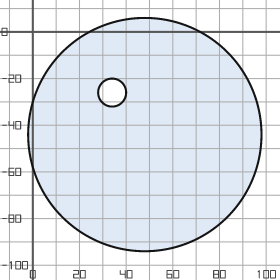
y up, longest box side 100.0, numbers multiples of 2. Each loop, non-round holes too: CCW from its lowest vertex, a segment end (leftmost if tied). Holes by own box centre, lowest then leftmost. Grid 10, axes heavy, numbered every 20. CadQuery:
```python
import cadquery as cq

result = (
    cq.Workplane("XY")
    .moveTo(48.0, -44.0)
    .circle(50.0)
    .moveTo(34.0, -26.0)
    .circle(6.0)
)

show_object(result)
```